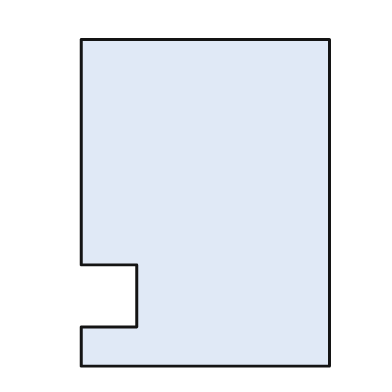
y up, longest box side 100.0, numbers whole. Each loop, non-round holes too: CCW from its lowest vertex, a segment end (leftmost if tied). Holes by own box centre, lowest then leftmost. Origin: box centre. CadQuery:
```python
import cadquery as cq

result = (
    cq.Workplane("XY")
    .moveTo(-38.0, -50.0)
    .lineTo(38.0, -50.0)
    .lineTo(38.0, 50.0)
    .lineTo(-38.0, 50.0)
    .lineTo(-38.0, -19.0)
    .lineTo(-21.0, -19.0)
    .lineTo(-21.0, -38.0)
    .lineTo(-38.0, -38.0)
    .close()
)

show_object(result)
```